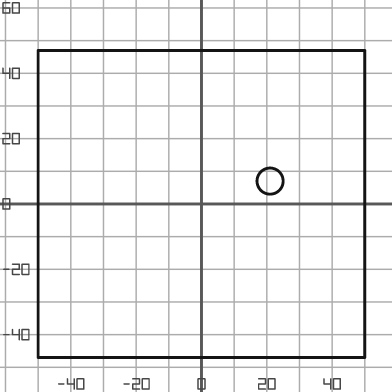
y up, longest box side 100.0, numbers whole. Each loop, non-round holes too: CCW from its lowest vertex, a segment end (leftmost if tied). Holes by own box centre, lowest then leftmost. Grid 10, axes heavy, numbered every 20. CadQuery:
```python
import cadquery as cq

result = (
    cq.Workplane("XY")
    .moveTo(-50.0, -47.0)
    .lineTo(50.0, -47.0)
    .lineTo(50.0, 47.0)
    .lineTo(-50.0, 47.0)
    .close()
    .moveTo(21.0, 7.0)
    .circle(4.0)
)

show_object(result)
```